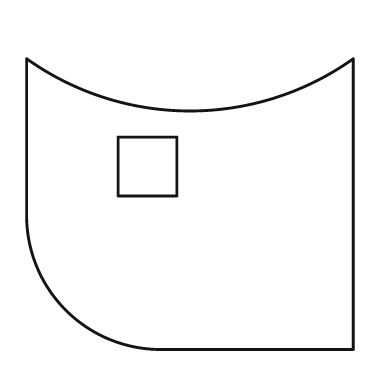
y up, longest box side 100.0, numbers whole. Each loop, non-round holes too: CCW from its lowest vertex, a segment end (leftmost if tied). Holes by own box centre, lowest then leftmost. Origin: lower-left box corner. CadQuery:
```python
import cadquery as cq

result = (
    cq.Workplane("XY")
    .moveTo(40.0, 0.0)
    .lineTo(100.0, 0.0)
    .lineTo(100.0, 89.0)
    .threePointArc((50.0, 73.0), (0.0, 89.0))
    .lineTo(0.0, 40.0)
    .threePointArc((12.0, 12.0), (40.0, 0.0))
    .close()
    .moveTo(28.0, 47.0)
    .lineTo(46.0, 47.0)
    .lineTo(46.0, 65.0)
    .lineTo(28.0, 65.0)
    .close()
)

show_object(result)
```